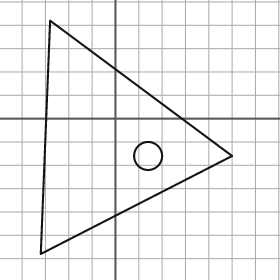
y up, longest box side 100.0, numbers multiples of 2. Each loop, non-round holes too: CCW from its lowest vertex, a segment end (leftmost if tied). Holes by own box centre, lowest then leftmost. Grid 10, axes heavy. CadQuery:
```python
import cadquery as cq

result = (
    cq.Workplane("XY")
    .moveTo(-32.0, -58.0)
    .lineTo(50.0, -16.0)
    .lineTo(-28.0, 42.0)
    .close()
    .moveTo(14.0, -16.0)
    .circle(6.0)
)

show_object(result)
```